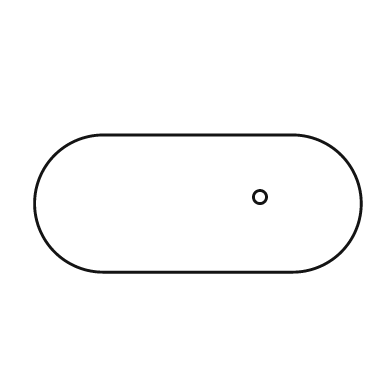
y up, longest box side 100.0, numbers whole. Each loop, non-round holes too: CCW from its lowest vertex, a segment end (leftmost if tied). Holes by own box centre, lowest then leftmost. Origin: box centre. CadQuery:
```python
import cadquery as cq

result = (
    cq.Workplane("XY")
    .moveTo(-29.0, -21.0)
    .lineTo(29.0, -21.0)
    .threePointArc((50.0, 0.0), (29.0, 21.0))
    .lineTo(-29.0, 21.0)
    .threePointArc((-50.0, 0.0), (-29.0, -21.0))
    .close()
    .moveTo(19.0, 2.0)
    .circle(2.0)
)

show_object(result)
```